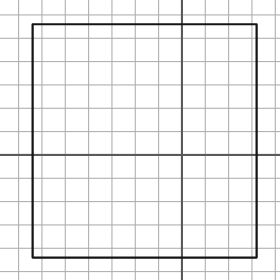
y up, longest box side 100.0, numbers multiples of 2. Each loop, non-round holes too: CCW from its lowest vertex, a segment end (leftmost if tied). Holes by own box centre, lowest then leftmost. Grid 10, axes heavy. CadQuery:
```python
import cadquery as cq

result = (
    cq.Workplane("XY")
    .moveTo(-64.0, -44.0)
    .lineTo(32.0, -44.0)
    .lineTo(32.0, 56.0)
    .lineTo(-64.0, 56.0)
    .close()
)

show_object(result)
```